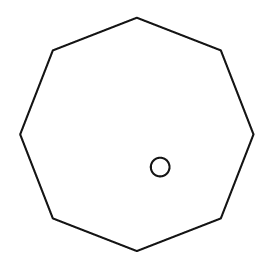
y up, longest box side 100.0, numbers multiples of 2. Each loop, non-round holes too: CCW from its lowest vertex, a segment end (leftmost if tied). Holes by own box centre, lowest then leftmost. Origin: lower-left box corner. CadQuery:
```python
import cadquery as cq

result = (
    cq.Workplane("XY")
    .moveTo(50.0, 0.0)
    .lineTo(86.0, 14.0)
    .lineTo(100.0, 50.0)
    .lineTo(86.0, 86.0)
    .lineTo(50.0, 100.0)
    .lineTo(14.0, 86.0)
    .lineTo(0.0, 50.0)
    .lineTo(14.0, 14.0)
    .close()
    .moveTo(60.0, 36.0)
    .circle(4.0)
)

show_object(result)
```